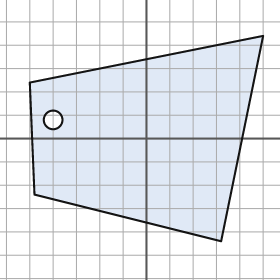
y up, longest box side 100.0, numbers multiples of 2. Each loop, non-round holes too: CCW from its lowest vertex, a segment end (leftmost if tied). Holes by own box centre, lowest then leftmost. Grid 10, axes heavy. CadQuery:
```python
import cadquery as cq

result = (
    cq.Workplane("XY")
    .moveTo(32.0, -44.0)
    .lineTo(50.0, 44.0)
    .lineTo(-50.0, 24.0)
    .lineTo(-48.0, -24.0)
    .close()
    .moveTo(-40.0, 8.0)
    .circle(4.0)
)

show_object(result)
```